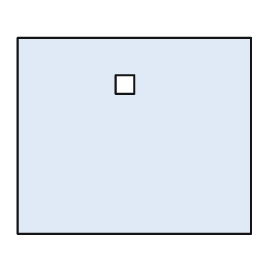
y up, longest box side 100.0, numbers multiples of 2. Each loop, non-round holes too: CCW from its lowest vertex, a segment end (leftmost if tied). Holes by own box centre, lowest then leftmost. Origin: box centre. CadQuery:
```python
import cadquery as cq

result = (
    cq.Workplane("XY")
    .moveTo(-50.0, -42.0)
    .lineTo(50.0, -42.0)
    .lineTo(50.0, 42.0)
    .lineTo(-50.0, 42.0)
    .close()
    .moveTo(-8.0, 18.0)
    .lineTo(0.0, 18.0)
    .lineTo(0.0, 26.0)
    .lineTo(-8.0, 26.0)
    .close()
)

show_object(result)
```